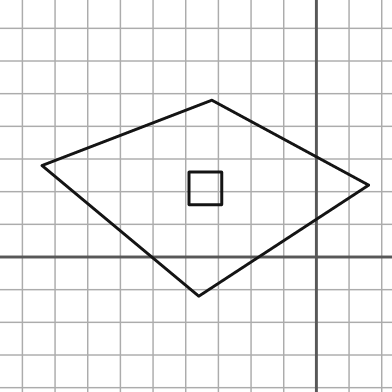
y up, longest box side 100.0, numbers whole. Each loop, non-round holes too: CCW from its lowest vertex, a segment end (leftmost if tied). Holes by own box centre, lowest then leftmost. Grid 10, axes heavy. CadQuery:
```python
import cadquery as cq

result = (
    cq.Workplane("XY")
    .moveTo(-36.0, -12.0)
    .lineTo(16.0, 22.0)
    .lineTo(-32.0, 48.0)
    .lineTo(-84.0, 28.0)
    .close()
    .moveTo(-39.0, 16.0)
    .lineTo(-29.0, 16.0)
    .lineTo(-29.0, 26.0)
    .lineTo(-39.0, 26.0)
    .close()
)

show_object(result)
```